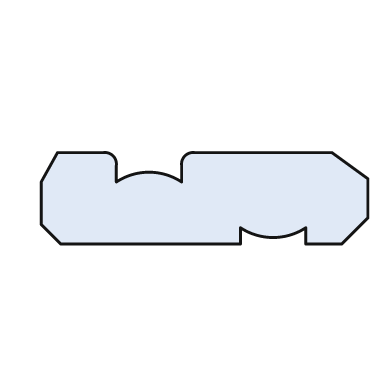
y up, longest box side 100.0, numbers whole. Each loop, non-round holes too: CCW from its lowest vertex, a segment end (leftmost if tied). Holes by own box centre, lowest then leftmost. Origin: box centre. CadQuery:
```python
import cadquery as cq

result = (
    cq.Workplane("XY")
    .moveTo(-44.0, -14.0)
    .lineTo(11.0, -14.0)
    .lineTo(11.0, -9.0)
    .threePointArc((21.0, -12.0), (31.0, -9.0))
    .lineTo(31.0, -14.0)
    .lineTo(42.0, -14.0)
    .lineTo(50.0, -6.0)
    .lineTo(50.0, 6.0)
    .lineTo(39.0, 14.0)
    .lineTo(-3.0, 14.0)
    .threePointArc((-6.0, 13.0), (-7.0, 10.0))
    .lineTo(-7.0, 5.0)
    .threePointArc((-17.0, 8.0), (-27.0, 5.0))
    .lineTo(-27.0, 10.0)
    .threePointArc((-28.0, 13.0), (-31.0, 14.0))
    .lineTo(-45.0, 14.0)
    .lineTo(-50.0, 5.0)
    .lineTo(-50.0, -8.0)
    .close()
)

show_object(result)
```